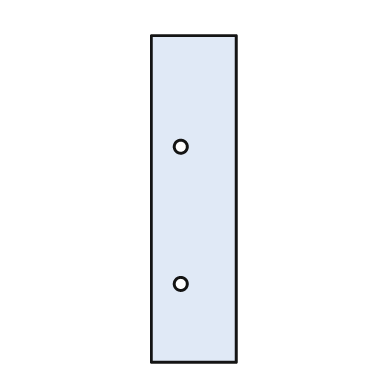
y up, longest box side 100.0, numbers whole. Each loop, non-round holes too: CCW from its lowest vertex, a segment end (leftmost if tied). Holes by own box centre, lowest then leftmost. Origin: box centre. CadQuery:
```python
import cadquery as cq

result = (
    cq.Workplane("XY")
    .moveTo(-13.0, -50.0)
    .lineTo(13.0, -50.0)
    .lineTo(13.0, 50.0)
    .lineTo(-13.0, 50.0)
    .close()
    .moveTo(-4.0, -26.0)
    .circle(2.0)
    .moveTo(-4.0, 16.0)
    .circle(2.0)
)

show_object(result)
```